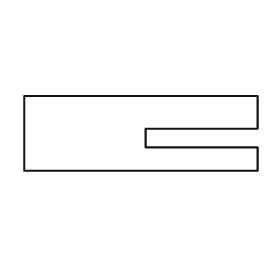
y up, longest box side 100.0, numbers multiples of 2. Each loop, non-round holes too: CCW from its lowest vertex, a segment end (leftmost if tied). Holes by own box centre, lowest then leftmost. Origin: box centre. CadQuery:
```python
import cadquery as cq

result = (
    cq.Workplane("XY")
    .moveTo(-50.0, -16.0)
    .lineTo(50.0, -16.0)
    .lineTo(50.0, -6.0)
    .lineTo(2.0, -6.0)
    .lineTo(2.0, 2.0)
    .lineTo(50.0, 2.0)
    .lineTo(50.0, 16.0)
    .lineTo(-50.0, 16.0)
    .close()
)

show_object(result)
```